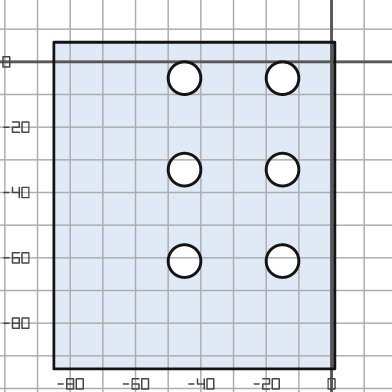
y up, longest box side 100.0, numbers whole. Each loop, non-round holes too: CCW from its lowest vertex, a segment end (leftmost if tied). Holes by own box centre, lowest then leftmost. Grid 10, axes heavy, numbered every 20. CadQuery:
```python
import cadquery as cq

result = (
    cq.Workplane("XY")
    .moveTo(-85.0, -94.0)
    .lineTo(1.0, -94.0)
    .lineTo(1.0, 6.0)
    .lineTo(-85.0, 6.0)
    .close()
    .moveTo(-45.0, -61.0)
    .circle(5.0)
    .moveTo(-15.0, -61.0)
    .circle(5.0)
    .moveTo(-45.0, -33.0)
    .circle(5.0)
    .moveTo(-15.0, -33.0)
    .circle(5.0)
    .moveTo(-45.0, -5.0)
    .circle(5.0)
    .moveTo(-15.0, -5.0)
    .circle(5.0)
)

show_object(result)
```